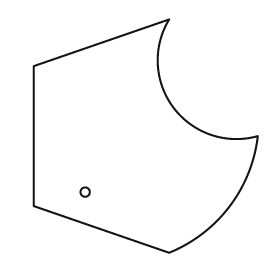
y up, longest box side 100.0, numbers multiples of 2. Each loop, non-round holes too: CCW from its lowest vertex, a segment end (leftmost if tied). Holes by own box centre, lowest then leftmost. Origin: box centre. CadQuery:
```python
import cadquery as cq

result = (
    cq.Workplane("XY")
    .moveTo(10.0, -50.0)
    .threePointArc((36.0, -30.0), (48.0, 0.0))
    .threePointArc((12.0, 12.0), (10.0, 50.0))
    .lineTo(-48.0, 30.0)
    .lineTo(-48.0, -30.0)
    .close()
    .moveTo(-26.0, -24.0)
    .circle(2.0)
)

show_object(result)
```